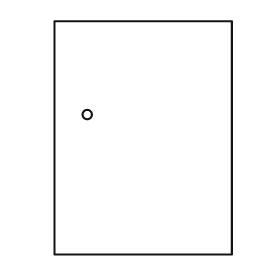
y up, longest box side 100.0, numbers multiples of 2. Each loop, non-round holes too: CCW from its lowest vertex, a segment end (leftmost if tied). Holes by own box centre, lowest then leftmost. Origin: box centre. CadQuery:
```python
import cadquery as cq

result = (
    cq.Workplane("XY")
    .moveTo(-38.0, -50.0)
    .lineTo(38.0, -50.0)
    .lineTo(38.0, 50.0)
    .lineTo(-38.0, 50.0)
    .close()
    .moveTo(-24.0, 10.0)
    .circle(2.0)
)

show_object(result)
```